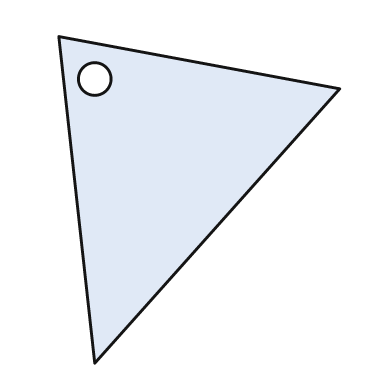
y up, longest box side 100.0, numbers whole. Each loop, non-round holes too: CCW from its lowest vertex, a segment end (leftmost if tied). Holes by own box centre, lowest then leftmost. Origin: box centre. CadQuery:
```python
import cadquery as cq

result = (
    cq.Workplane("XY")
    .moveTo(-32.0, -50.0)
    .lineTo(43.0, 34.0)
    .lineTo(-43.0, 50.0)
    .close()
    .moveTo(-32.0, 37.0)
    .circle(5.0)
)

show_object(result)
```